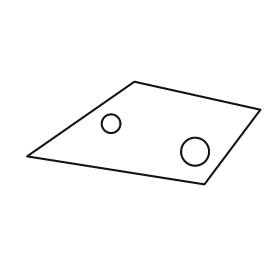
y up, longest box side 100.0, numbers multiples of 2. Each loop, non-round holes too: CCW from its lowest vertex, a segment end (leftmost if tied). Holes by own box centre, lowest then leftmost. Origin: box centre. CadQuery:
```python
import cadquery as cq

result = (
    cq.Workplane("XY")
    .moveTo(26.0, -22.0)
    .lineTo(50.0, 10.0)
    .lineTo(-4.0, 22.0)
    .lineTo(-50.0, -10.0)
    .close()
    .moveTo(22.0, -8.0)
    .circle(6.0)
    .moveTo(-14.0, 4.0)
    .circle(4.0)
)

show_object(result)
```